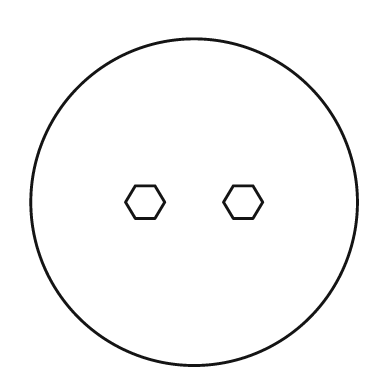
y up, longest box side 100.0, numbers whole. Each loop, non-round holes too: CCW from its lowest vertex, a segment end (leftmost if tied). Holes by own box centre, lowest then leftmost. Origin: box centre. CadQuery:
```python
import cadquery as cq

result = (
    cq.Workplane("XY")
    .moveTo(0.0, 0.0)
    .circle(50.0)
    .moveTo(-18.0, -5.0)
    .lineTo(-12.0, -5.0)
    .lineTo(-9.0, 0.0)
    .lineTo(-12.0, 5.0)
    .lineTo(-18.0, 5.0)
    .lineTo(-21.0, 0.0)
    .close()
    .moveTo(12.0, -5.0)
    .lineTo(18.0, -5.0)
    .lineTo(21.0, 0.0)
    .lineTo(18.0, 5.0)
    .lineTo(12.0, 5.0)
    .lineTo(9.0, 0.0)
    .close()
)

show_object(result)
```